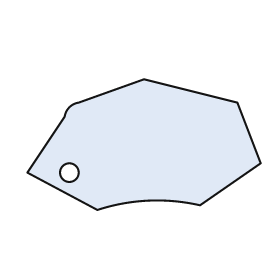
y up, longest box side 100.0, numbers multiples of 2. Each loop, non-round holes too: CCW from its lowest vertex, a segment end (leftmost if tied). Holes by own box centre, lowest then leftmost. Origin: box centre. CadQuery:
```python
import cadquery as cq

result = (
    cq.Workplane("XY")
    .moveTo(-20.0, -28.0)
    .threePointArc((2.0, -24.0), (24.0, -26.0))
    .lineTo(50.0, -8.0)
    .lineTo(40.0, 18.0)
    .lineTo(0.0, 28.0)
    .lineTo(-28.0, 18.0)
    .threePointArc((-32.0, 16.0), (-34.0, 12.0))
    .lineTo(-50.0, -12.0)
    .close()
    .moveTo(-32.0, -12.0)
    .circle(4.0)
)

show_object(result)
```